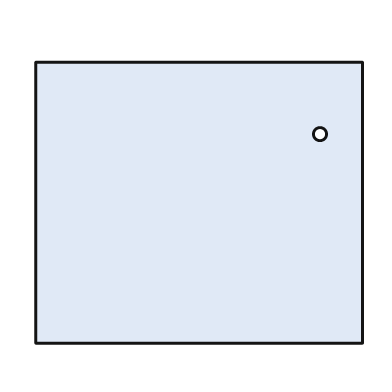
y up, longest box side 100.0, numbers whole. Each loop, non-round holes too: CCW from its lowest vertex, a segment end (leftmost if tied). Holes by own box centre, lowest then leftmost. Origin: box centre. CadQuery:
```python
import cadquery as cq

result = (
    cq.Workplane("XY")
    .moveTo(-50.0, -43.0)
    .lineTo(50.0, -43.0)
    .lineTo(50.0, 43.0)
    .lineTo(-50.0, 43.0)
    .close()
    .moveTo(37.0, 21.0)
    .circle(2.0)
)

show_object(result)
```